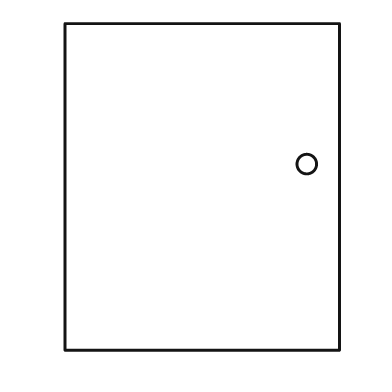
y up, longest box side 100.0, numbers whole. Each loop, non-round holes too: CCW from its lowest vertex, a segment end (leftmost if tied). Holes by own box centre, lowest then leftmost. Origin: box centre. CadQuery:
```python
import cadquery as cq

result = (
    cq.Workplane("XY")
    .moveTo(-42.0, -50.0)
    .lineTo(42.0, -50.0)
    .lineTo(42.0, 50.0)
    .lineTo(-42.0, 50.0)
    .close()
    .moveTo(32.0, 7.0)
    .circle(3.0)
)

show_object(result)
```